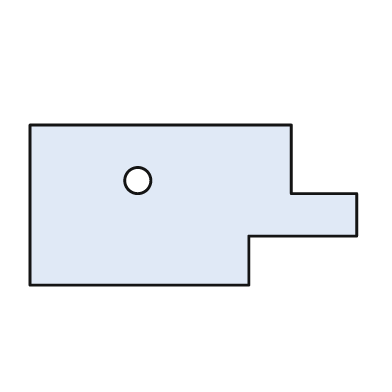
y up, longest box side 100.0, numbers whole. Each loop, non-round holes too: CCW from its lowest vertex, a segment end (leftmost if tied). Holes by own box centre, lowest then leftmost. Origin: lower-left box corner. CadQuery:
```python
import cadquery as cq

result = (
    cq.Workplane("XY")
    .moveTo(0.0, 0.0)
    .lineTo(67.0, 0.0)
    .lineTo(67.0, 15.0)
    .lineTo(100.0, 15.0)
    .lineTo(100.0, 28.0)
    .lineTo(80.0, 28.0)
    .lineTo(80.0, 49.0)
    .lineTo(0.0, 49.0)
    .close()
    .moveTo(33.0, 32.0)
    .circle(4.0)
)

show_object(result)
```